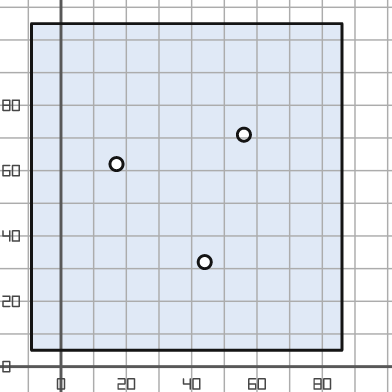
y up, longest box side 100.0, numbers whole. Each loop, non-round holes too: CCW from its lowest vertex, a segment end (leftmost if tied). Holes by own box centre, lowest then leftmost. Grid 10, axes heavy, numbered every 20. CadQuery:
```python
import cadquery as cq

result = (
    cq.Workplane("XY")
    .moveTo(-9.0, 5.0)
    .lineTo(86.0, 5.0)
    .lineTo(86.0, 105.0)
    .lineTo(-9.0, 105.0)
    .close()
    .moveTo(44.0, 32.0)
    .circle(2.0)
    .moveTo(17.0, 62.0)
    .circle(2.0)
    .moveTo(56.0, 71.0)
    .circle(2.0)
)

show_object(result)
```